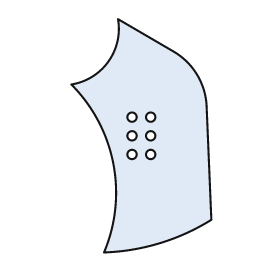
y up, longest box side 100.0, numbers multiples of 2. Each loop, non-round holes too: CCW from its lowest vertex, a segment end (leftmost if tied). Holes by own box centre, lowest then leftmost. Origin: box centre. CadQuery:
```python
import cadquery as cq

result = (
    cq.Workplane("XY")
    .moveTo(-16.0, -50.0)
    .threePointArc((8.0, -46.0), (30.0, -36.0))
    .lineTo(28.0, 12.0)
    .threePointArc((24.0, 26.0), (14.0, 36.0))
    .lineTo(-10.0, 50.0)
    .threePointArc((-14.0, 32.0), (-30.0, 22.0))
    .threePointArc((-12.0, -12.0), (-16.0, -50.0))
    .close()
    .moveTo(-4.0, -8.0)
    .circle(2.0)
    .moveTo(4.0, -8.0)
    .circle(2.0)
    .moveTo(-4.0, 0.0)
    .circle(2.0)
    .moveTo(4.0, 0.0)
    .circle(2.0)
    .moveTo(-4.0, 8.0)
    .circle(2.0)
    .moveTo(4.0, 8.0)
    .circle(2.0)
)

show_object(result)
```